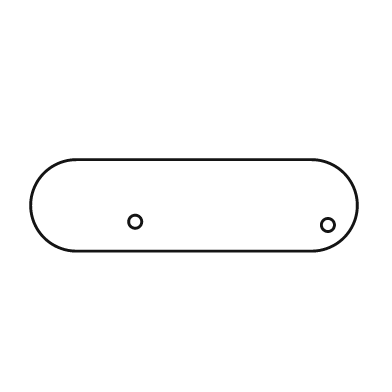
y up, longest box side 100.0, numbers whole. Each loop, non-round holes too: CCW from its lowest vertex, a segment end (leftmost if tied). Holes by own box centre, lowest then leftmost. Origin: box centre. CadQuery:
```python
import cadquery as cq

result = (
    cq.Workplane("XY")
    .moveTo(-36.0, -14.0)
    .lineTo(36.0, -14.0)
    .threePointArc((50.0, 0.0), (36.0, 14.0))
    .lineTo(-36.0, 14.0)
    .threePointArc((-50.0, 0.0), (-36.0, -14.0))
    .close()
    .moveTo(41.0, -6.0)
    .circle(2.0)
    .moveTo(-18.0, -5.0)
    .circle(2.0)
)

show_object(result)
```